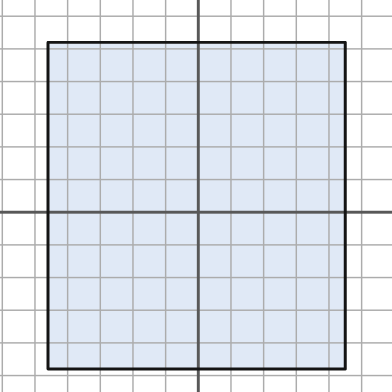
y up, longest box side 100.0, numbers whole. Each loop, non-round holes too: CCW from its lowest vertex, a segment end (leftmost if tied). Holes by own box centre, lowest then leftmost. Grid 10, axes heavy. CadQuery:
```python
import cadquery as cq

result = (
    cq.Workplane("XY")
    .moveTo(-46.0, -48.0)
    .lineTo(45.0, -48.0)
    .lineTo(45.0, 52.0)
    .lineTo(-46.0, 52.0)
    .close()
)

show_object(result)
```